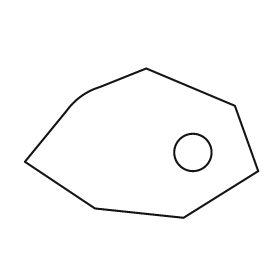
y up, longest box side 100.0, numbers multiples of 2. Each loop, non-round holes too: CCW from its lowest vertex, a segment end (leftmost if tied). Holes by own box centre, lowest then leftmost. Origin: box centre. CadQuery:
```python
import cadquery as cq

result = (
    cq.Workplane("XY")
    .moveTo(18.0, -32.0)
    .lineTo(50.0, -12.0)
    .lineTo(40.0, 16.0)
    .lineTo(2.0, 32.0)
    .lineTo(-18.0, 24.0)
    .threePointArc((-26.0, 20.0), (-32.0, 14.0))
    .lineTo(-50.0, -8.0)
    .lineTo(-20.0, -28.0)
    .close()
    .moveTo(22.0, -4.0)
    .circle(8.0)
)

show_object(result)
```